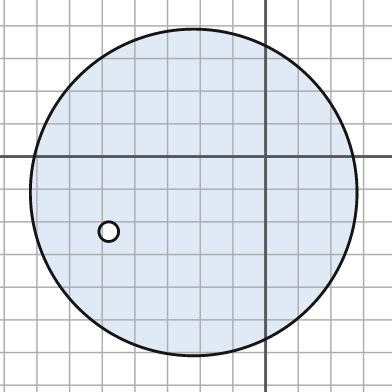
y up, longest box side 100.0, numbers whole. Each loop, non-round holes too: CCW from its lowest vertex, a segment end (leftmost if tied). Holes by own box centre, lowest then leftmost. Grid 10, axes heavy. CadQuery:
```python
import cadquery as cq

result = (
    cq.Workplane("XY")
    .moveTo(-22.0, -11.0)
    .circle(50.0)
    .moveTo(-48.0, -23.0)
    .circle(3.0)
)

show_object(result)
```